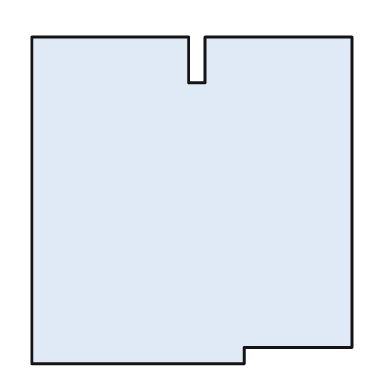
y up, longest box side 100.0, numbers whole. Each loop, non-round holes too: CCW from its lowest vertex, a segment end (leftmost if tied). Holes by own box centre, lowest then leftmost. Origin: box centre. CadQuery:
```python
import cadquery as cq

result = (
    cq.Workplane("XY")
    .moveTo(-49.0, -50.0)
    .lineTo(16.0, -50.0)
    .lineTo(16.0, -45.0)
    .lineTo(49.0, -45.0)
    .lineTo(49.0, 50.0)
    .lineTo(4.0, 50.0)
    .lineTo(4.0, 36.0)
    .lineTo(-1.0, 36.0)
    .lineTo(-1.0, 50.0)
    .lineTo(-49.0, 50.0)
    .close()
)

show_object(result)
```